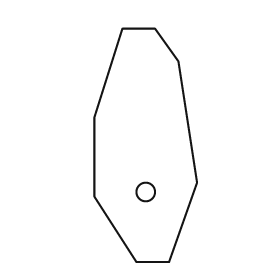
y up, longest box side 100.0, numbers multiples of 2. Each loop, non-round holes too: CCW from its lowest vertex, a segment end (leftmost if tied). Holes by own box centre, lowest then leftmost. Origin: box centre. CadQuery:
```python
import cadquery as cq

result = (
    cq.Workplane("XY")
    .moveTo(-4.0, -50.0)
    .lineTo(10.0, -50.0)
    .lineTo(22.0, -16.0)
    .lineTo(14.0, 36.0)
    .lineTo(4.0, 50.0)
    .lineTo(-10.0, 50.0)
    .lineTo(-22.0, 12.0)
    .lineTo(-22.0, -22.0)
    .close()
    .moveTo(0.0, -20.0)
    .circle(4.0)
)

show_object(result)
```